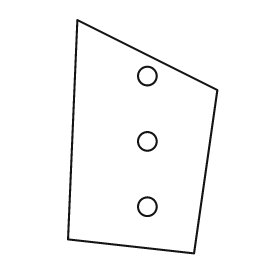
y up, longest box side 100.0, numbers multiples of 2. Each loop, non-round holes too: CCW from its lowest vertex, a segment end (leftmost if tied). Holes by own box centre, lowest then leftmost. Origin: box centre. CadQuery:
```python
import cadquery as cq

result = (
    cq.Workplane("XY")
    .moveTo(22.0, -50.0)
    .lineTo(32.0, 20.0)
    .lineTo(-28.0, 50.0)
    .lineTo(-32.0, -44.0)
    .close()
    .moveTo(2.0, -30.0)
    .circle(4.0)
    .moveTo(2.0, -2.0)
    .circle(4.0)
    .moveTo(2.0, 26.0)
    .circle(4.0)
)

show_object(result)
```